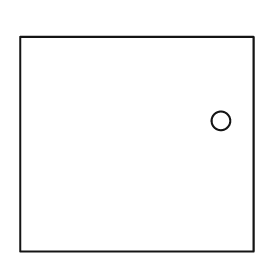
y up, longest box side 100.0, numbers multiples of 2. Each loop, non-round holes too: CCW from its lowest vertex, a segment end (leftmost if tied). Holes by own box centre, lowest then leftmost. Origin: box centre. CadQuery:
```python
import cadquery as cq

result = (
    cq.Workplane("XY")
    .moveTo(-50.0, -46.0)
    .lineTo(50.0, -46.0)
    .lineTo(50.0, 46.0)
    .lineTo(-50.0, 46.0)
    .close()
    .moveTo(36.0, 10.0)
    .circle(4.0)
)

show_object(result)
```